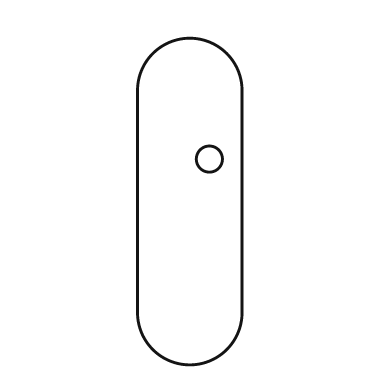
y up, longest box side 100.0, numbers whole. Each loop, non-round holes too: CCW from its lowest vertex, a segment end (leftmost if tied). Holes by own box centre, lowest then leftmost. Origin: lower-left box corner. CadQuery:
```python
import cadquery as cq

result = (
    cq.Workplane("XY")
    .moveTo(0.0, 16.0)
    .threePointArc((16.0, 0.0), (32.0, 16.0))
    .lineTo(32.0, 84.0)
    .threePointArc((16.0, 100.0), (0.0, 84.0))
    .close()
    .moveTo(22.0, 63.0)
    .circle(4.0)
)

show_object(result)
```